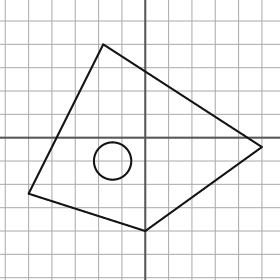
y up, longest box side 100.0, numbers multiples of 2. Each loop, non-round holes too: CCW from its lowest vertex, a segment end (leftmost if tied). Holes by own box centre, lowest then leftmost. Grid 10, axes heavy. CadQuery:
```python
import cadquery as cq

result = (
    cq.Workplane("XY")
    .moveTo(0.0, -40.0)
    .lineTo(50.0, -4.0)
    .lineTo(-18.0, 40.0)
    .lineTo(-50.0, -24.0)
    .close()
    .moveTo(-14.0, -10.0)
    .circle(8.0)
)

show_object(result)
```